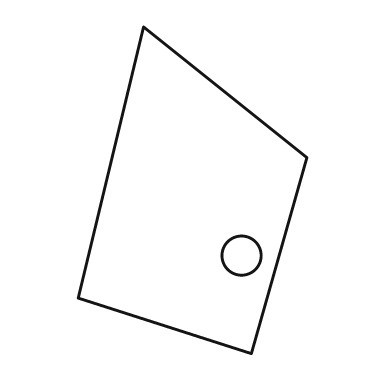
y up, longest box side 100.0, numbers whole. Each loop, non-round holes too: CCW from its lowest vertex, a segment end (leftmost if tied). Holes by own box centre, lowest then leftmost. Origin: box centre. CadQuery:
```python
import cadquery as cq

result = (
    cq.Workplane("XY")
    .moveTo(18.0, -50.0)
    .lineTo(35.0, 10.0)
    .lineTo(-15.0, 50.0)
    .lineTo(-35.0, -33.0)
    .close()
    .moveTo(15.0, -20.0)
    .circle(6.0)
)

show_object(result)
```